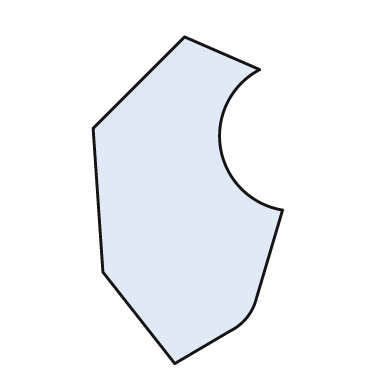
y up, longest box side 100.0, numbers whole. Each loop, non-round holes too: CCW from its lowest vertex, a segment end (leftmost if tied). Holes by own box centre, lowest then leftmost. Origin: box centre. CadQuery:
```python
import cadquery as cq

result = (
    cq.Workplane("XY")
    .moveTo(-4.0, -50.0)
    .lineTo(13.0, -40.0)
    .threePointArc((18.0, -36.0), (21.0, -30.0))
    .lineTo(29.0, -3.0)
    .threePointArc((10.0, 16.0), (22.0, 40.0))
    .lineTo(-1.0, 50.0)
    .lineTo(-29.0, 22.0)
    .lineTo(-26.0, -22.0)
    .close()
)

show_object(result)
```